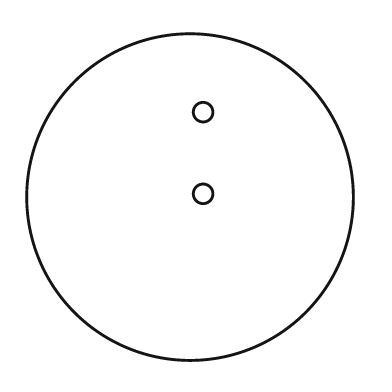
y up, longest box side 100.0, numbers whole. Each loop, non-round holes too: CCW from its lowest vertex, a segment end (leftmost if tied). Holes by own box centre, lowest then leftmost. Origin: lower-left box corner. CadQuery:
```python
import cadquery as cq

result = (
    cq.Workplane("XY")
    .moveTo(50.0, 50.0)
    .circle(50.0)
    .moveTo(54.0, 51.0)
    .circle(3.0)
    .moveTo(54.0, 76.0)
    .circle(3.0)
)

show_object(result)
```